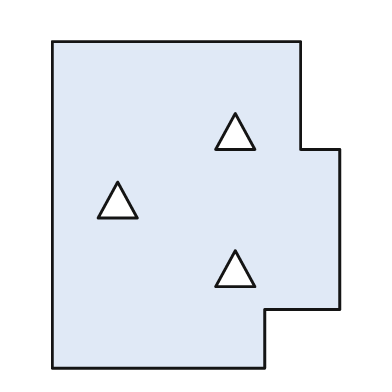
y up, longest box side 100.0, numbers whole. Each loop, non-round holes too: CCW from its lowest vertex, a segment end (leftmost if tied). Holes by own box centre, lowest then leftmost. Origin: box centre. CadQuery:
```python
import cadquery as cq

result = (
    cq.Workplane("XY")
    .moveTo(-44.0, -50.0)
    .lineTo(21.0, -50.0)
    .lineTo(21.0, -32.0)
    .lineTo(44.0, -32.0)
    .lineTo(44.0, 17.0)
    .lineTo(32.0, 17.0)
    .lineTo(32.0, 50.0)
    .lineTo(-44.0, 50.0)
    .close()
    .moveTo(6.0, -25.0)
    .lineTo(18.0, -25.0)
    .lineTo(12.0, -14.0)
    .close()
    .moveTo(-30.0, -4.0)
    .lineTo(-18.0, -4.0)
    .lineTo(-24.0, 7.0)
    .close()
    .moveTo(6.0, 17.0)
    .lineTo(18.0, 17.0)
    .lineTo(12.0, 28.0)
    .close()
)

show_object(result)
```